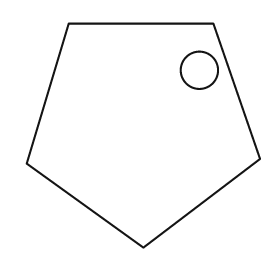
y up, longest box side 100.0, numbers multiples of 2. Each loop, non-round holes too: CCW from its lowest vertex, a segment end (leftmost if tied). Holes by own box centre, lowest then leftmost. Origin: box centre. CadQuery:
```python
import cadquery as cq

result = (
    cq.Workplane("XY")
    .moveTo(0.0, -48.0)
    .lineTo(50.0, -10.0)
    .lineTo(30.0, 48.0)
    .lineTo(-32.0, 48.0)
    .lineTo(-50.0, -12.0)
    .close()
    .moveTo(24.0, 28.0)
    .circle(8.0)
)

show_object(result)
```